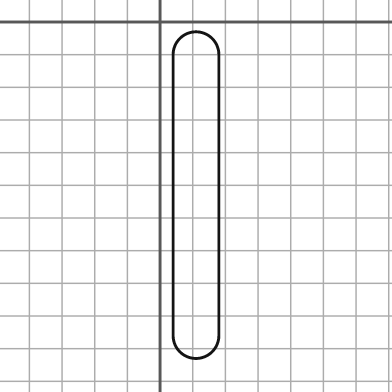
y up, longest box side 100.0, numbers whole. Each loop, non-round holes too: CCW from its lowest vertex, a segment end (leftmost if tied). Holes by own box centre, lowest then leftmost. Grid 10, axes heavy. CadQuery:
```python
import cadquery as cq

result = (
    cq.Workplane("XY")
    .moveTo(4.0, -96.0)
    .threePointArc((11.0, -103.0), (18.0, -96.0))
    .lineTo(18.0, -10.0)
    .threePointArc((11.0, -3.0), (4.0, -10.0))
    .close()
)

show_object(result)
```